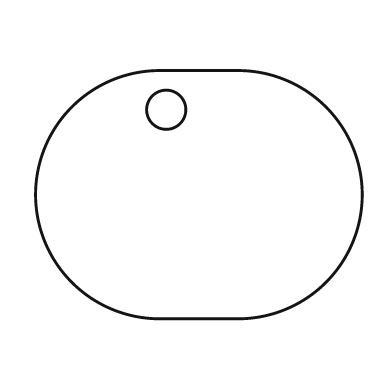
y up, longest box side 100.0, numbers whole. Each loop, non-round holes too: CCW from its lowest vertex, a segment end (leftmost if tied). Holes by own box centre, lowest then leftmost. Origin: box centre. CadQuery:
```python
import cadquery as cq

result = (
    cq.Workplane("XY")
    .moveTo(-12.0, -38.0)
    .lineTo(12.0, -38.0)
    .threePointArc((50.0, 0.0), (12.0, 38.0))
    .lineTo(-12.0, 38.0)
    .threePointArc((-50.0, 0.0), (-12.0, -38.0))
    .close()
    .moveTo(-10.0, 26.0)
    .circle(6.0)
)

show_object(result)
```